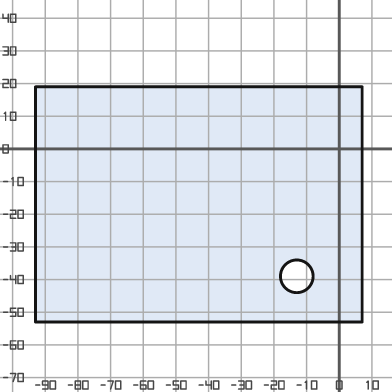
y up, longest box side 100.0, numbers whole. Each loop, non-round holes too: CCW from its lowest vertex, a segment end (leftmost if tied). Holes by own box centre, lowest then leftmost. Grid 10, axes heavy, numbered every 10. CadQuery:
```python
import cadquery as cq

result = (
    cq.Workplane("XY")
    .moveTo(-93.0, -53.0)
    .lineTo(7.0, -53.0)
    .lineTo(7.0, 19.0)
    .lineTo(-93.0, 19.0)
    .close()
    .moveTo(-13.0, -39.0)
    .circle(5.0)
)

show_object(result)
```